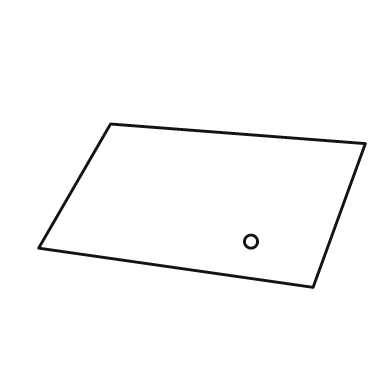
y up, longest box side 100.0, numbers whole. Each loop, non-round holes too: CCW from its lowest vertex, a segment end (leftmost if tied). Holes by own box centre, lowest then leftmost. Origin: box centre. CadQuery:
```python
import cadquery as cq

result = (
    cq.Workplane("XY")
    .moveTo(34.0, -25.0)
    .lineTo(50.0, 19.0)
    .lineTo(-28.0, 25.0)
    .lineTo(-50.0, -13.0)
    .close()
    .moveTo(15.0, -11.0)
    .circle(2.0)
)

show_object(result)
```